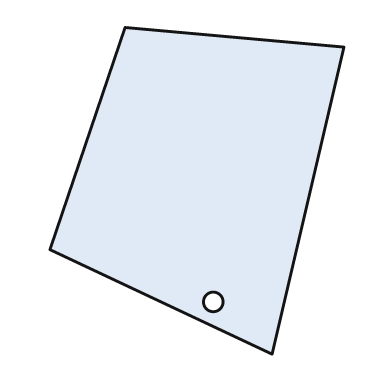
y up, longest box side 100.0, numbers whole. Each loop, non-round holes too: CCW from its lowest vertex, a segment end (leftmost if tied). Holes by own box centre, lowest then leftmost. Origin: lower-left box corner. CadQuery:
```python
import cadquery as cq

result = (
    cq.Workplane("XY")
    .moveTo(68.0, 0.0)
    .lineTo(90.0, 94.0)
    .lineTo(23.0, 100.0)
    .lineTo(0.0, 32.0)
    .close()
    .moveTo(50.0, 16.0)
    .circle(3.0)
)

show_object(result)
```